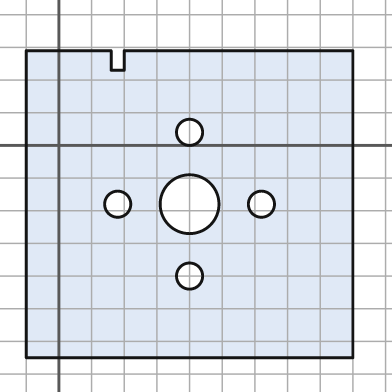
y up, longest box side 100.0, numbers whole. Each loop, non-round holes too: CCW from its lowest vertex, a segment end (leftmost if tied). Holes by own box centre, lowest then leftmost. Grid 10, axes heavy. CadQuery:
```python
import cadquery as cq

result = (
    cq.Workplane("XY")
    .moveTo(-10.0, -65.0)
    .lineTo(90.0, -65.0)
    .lineTo(90.0, 29.0)
    .lineTo(20.0, 29.0)
    .lineTo(20.0, 23.0)
    .lineTo(16.0, 23.0)
    .lineTo(16.0, 29.0)
    .lineTo(-10.0, 29.0)
    .close()
    .moveTo(40.0, -40.0)
    .circle(4.0)
    .moveTo(18.0, -18.0)
    .circle(4.0)
    .moveTo(40.0, -18.0)
    .circle(9.0)
    .moveTo(62.0, -18.0)
    .circle(4.0)
    .moveTo(40.0, 4.0)
    .circle(4.0)
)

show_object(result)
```